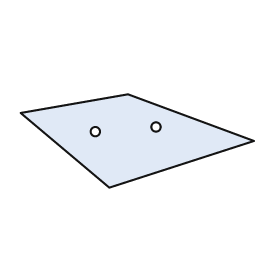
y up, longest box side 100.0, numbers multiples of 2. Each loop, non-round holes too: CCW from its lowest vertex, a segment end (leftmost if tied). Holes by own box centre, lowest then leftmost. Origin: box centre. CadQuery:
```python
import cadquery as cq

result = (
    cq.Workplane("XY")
    .moveTo(-12.0, -20.0)
    .lineTo(50.0, 0.0)
    .lineTo(-4.0, 20.0)
    .lineTo(-50.0, 12.0)
    .close()
    .moveTo(-18.0, 4.0)
    .circle(2.0)
    .moveTo(8.0, 6.0)
    .circle(2.0)
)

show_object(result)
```